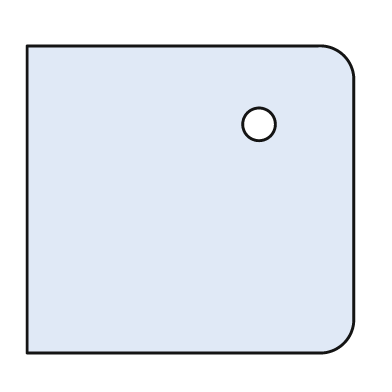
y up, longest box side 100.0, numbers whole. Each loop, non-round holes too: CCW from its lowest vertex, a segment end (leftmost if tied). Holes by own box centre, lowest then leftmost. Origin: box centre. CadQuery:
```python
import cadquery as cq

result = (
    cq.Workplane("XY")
    .moveTo(-50.0, -47.0)
    .lineTo(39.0, -47.0)
    .threePointArc((47.0, -44.0), (50.0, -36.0))
    .lineTo(50.0, 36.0)
    .threePointArc((47.0, 44.0), (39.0, 47.0))
    .lineTo(-50.0, 47.0)
    .close()
    .moveTo(21.0, 23.0)
    .circle(5.0)
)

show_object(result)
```